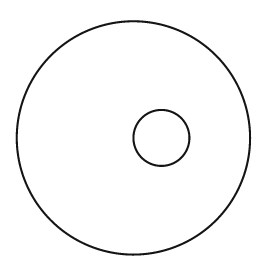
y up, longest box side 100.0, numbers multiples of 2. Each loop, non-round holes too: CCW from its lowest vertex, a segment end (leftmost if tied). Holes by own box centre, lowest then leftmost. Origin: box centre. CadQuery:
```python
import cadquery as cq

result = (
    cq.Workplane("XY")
    .moveTo(0.0, 0.0)
    .circle(50.0)
    .moveTo(12.0, 0.0)
    .circle(12.0)
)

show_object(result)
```